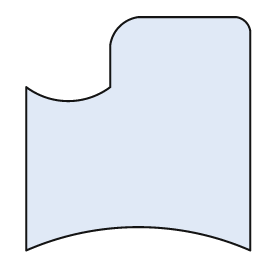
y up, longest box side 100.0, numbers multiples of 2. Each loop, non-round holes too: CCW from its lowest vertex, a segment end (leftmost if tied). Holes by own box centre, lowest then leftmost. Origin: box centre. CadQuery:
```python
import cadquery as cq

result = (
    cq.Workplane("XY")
    .moveTo(-48.0, -50.0)
    .threePointArc((0.0, -40.0), (48.0, -50.0))
    .lineTo(48.0, 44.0)
    .threePointArc((46.0, 48.0), (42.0, 50.0))
    .lineTo(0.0, 50.0)
    .threePointArc((-8.0, 46.0), (-12.0, 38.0))
    .lineTo(-12.0, 20.0)
    .threePointArc((-30.0, 14.0), (-48.0, 20.0))
    .close()
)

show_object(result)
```